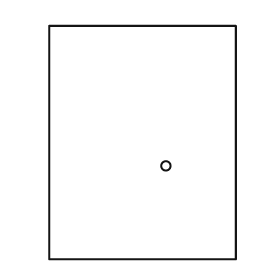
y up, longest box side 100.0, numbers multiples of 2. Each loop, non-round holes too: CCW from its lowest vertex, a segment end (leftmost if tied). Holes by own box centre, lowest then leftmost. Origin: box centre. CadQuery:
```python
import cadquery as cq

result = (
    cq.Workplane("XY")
    .moveTo(-40.0, -50.0)
    .lineTo(40.0, -50.0)
    .lineTo(40.0, 50.0)
    .lineTo(-40.0, 50.0)
    .close()
    .moveTo(10.0, -10.0)
    .circle(2.0)
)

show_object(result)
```